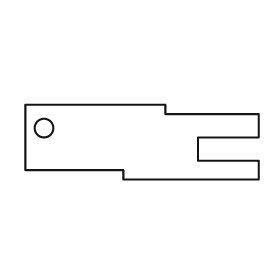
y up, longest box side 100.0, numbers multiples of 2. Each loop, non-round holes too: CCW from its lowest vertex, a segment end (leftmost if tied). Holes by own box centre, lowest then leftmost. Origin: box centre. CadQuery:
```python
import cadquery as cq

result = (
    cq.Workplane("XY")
    .moveTo(-8.0, -16.0)
    .lineTo(50.0, -16.0)
    .lineTo(50.0, -8.0)
    .lineTo(24.0, -8.0)
    .lineTo(24.0, 2.0)
    .lineTo(50.0, 2.0)
    .lineTo(50.0, 12.0)
    .lineTo(10.0, 12.0)
    .lineTo(10.0, 16.0)
    .lineTo(-50.0, 16.0)
    .lineTo(-50.0, -12.0)
    .lineTo(-8.0, -12.0)
    .close()
    .moveTo(-42.0, 6.0)
    .circle(4.0)
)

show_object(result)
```